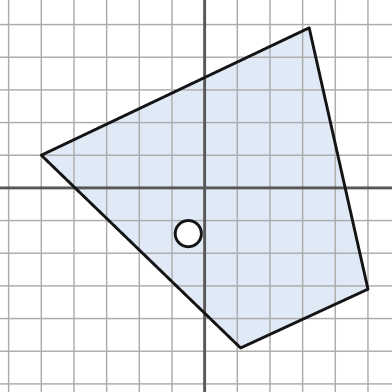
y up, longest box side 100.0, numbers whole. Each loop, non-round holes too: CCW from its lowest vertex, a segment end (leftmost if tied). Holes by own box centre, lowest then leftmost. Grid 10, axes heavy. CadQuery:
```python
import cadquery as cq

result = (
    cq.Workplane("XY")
    .moveTo(11.0, -49.0)
    .lineTo(50.0, -31.0)
    .lineTo(32.0, 49.0)
    .lineTo(-50.0, 10.0)
    .close()
    .moveTo(-5.0, -14.0)
    .circle(4.0)
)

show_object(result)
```